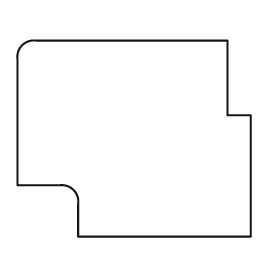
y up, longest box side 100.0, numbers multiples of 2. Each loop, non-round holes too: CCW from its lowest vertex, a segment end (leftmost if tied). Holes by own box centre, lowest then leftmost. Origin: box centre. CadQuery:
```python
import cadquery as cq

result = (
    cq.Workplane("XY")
    .moveTo(-24.0, -42.0)
    .lineTo(50.0, -42.0)
    .lineTo(50.0, 10.0)
    .lineTo(40.0, 10.0)
    .lineTo(40.0, 42.0)
    .lineTo(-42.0, 42.0)
    .threePointArc((-48.0, 40.0), (-50.0, 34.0))
    .lineTo(-50.0, -20.0)
    .lineTo(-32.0, -20.0)
    .threePointArc((-26.0, -22.0), (-24.0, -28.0))
    .close()
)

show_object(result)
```